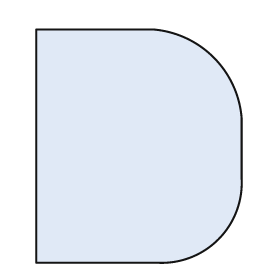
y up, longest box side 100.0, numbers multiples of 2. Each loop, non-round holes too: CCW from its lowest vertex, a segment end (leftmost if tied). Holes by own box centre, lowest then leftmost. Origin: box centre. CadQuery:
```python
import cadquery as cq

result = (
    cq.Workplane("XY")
    .moveTo(-44.0, -50.0)
    .lineTo(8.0, -50.0)
    .threePointArc((34.0, -40.0), (44.0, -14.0))
    .lineTo(44.0, 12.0)
    .threePointArc((32.0, 38.0), (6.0, 50.0))
    .lineTo(-44.0, 50.0)
    .close()
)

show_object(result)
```